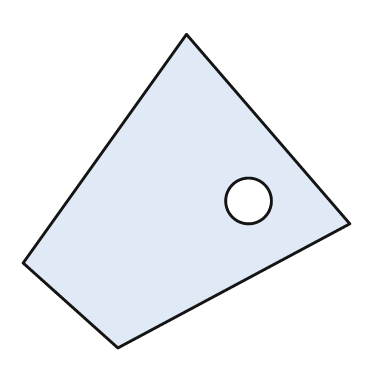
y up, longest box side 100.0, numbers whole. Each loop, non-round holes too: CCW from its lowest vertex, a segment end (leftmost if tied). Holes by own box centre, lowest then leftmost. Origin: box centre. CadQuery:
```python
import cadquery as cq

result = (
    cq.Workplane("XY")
    .moveTo(-21.0, -48.0)
    .lineTo(50.0, -10.0)
    .lineTo(0.0, 48.0)
    .lineTo(-50.0, -22.0)
    .close()
    .moveTo(19.0, -3.0)
    .circle(7.0)
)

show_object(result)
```